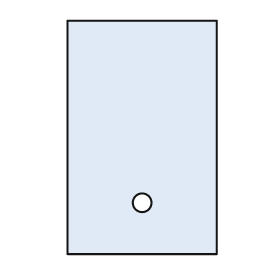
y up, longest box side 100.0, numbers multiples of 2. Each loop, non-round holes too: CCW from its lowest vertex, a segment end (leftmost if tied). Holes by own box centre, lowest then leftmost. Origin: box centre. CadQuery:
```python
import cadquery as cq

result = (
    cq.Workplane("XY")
    .moveTo(-32.0, -50.0)
    .lineTo(32.0, -50.0)
    .lineTo(32.0, 50.0)
    .lineTo(-32.0, 50.0)
    .close()
    .moveTo(0.0, -28.0)
    .circle(4.0)
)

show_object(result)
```